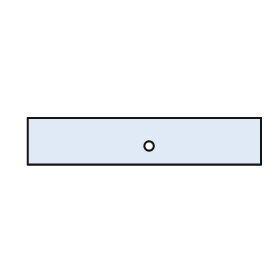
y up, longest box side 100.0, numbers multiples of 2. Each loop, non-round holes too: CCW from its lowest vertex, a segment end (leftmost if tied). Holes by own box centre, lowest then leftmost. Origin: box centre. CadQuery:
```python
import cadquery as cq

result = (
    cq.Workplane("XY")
    .moveTo(-50.0, -10.0)
    .lineTo(50.0, -10.0)
    .lineTo(50.0, 10.0)
    .lineTo(-50.0, 10.0)
    .close()
    .moveTo(2.0, -2.0)
    .circle(2.0)
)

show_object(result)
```